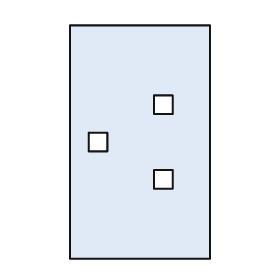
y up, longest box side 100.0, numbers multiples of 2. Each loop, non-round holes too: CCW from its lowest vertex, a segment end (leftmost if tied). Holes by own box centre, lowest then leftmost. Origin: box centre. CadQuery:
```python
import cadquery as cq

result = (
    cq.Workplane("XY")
    .moveTo(-30.0, -50.0)
    .lineTo(30.0, -50.0)
    .lineTo(30.0, 50.0)
    .lineTo(-30.0, 50.0)
    .close()
    .moveTo(6.0, -20.0)
    .lineTo(14.0, -20.0)
    .lineTo(14.0, -12.0)
    .lineTo(6.0, -12.0)
    .close()
    .moveTo(-22.0, -4.0)
    .lineTo(-14.0, -4.0)
    .lineTo(-14.0, 4.0)
    .lineTo(-22.0, 4.0)
    .close()
    .moveTo(6.0, 12.0)
    .lineTo(14.0, 12.0)
    .lineTo(14.0, 20.0)
    .lineTo(6.0, 20.0)
    .close()
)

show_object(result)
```